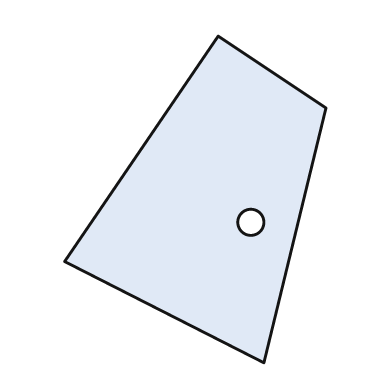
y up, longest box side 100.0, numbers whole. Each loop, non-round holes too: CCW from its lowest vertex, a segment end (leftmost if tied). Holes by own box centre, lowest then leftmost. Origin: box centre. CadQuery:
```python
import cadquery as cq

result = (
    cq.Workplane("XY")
    .moveTo(21.0, -50.0)
    .lineTo(40.0, 28.0)
    .lineTo(7.0, 50.0)
    .lineTo(-40.0, -19.0)
    .close()
    .moveTo(17.0, -7.0)
    .circle(4.0)
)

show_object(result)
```